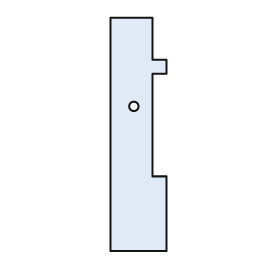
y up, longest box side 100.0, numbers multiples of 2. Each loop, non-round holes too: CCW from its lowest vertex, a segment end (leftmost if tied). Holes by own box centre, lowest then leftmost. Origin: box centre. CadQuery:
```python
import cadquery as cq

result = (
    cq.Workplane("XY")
    .moveTo(-12.0, -50.0)
    .lineTo(12.0, -50.0)
    .lineTo(12.0, -18.0)
    .lineTo(6.0, -18.0)
    .lineTo(6.0, 26.0)
    .lineTo(12.0, 26.0)
    .lineTo(12.0, 32.0)
    .lineTo(6.0, 32.0)
    .lineTo(6.0, 50.0)
    .lineTo(-12.0, 50.0)
    .close()
    .moveTo(-2.0, 12.0)
    .circle(2.0)
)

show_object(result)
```